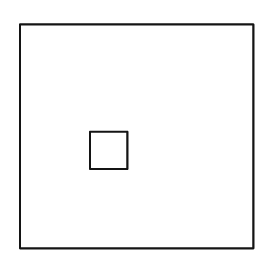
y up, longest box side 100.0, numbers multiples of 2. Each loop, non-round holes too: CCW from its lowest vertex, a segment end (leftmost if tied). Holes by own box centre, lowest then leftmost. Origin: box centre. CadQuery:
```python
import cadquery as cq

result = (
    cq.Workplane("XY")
    .moveTo(-50.0, -48.0)
    .lineTo(50.0, -48.0)
    .lineTo(50.0, 48.0)
    .lineTo(-50.0, 48.0)
    .close()
    .moveTo(-20.0, -14.0)
    .lineTo(-4.0, -14.0)
    .lineTo(-4.0, 2.0)
    .lineTo(-20.0, 2.0)
    .close()
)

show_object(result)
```